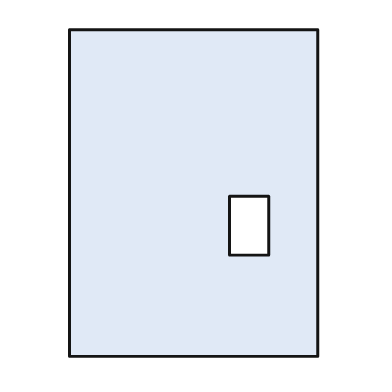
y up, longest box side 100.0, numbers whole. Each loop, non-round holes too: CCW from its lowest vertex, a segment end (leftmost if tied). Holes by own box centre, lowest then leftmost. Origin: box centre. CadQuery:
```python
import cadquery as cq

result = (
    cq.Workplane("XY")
    .moveTo(-38.0, -50.0)
    .lineTo(38.0, -50.0)
    .lineTo(38.0, 50.0)
    .lineTo(-38.0, 50.0)
    .close()
    .moveTo(11.0, -19.0)
    .lineTo(23.0, -19.0)
    .lineTo(23.0, -1.0)
    .lineTo(11.0, -1.0)
    .close()
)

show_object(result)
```